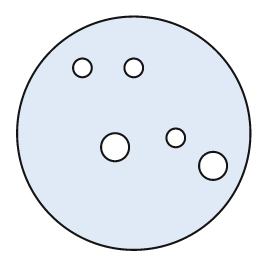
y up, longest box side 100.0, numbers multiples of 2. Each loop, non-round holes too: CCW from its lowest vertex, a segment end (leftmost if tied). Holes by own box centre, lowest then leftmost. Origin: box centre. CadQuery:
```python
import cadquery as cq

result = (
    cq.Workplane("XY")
    .moveTo(0.0, 0.0)
    .circle(50.0)
    .moveTo(34.0, -14.0)
    .circle(6.0)
    .moveTo(-8.0, -6.0)
    .circle(6.0)
    .moveTo(18.0, -2.0)
    .circle(4.0)
    .moveTo(-22.0, 28.0)
    .circle(4.0)
    .moveTo(0.0, 28.0)
    .circle(4.0)
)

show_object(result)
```